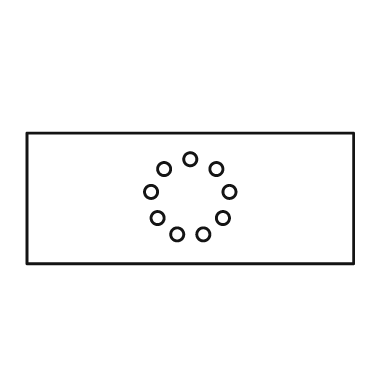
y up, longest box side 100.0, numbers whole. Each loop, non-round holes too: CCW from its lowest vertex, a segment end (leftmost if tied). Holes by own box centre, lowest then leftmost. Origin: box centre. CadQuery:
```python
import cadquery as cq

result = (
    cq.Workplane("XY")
    .moveTo(-50.0, -20.0)
    .lineTo(50.0, -20.0)
    .lineTo(50.0, 20.0)
    .lineTo(-50.0, 20.0)
    .close()
    .moveTo(-4.0, -11.0)
    .circle(2.0)
    .moveTo(4.0, -11.0)
    .circle(2.0)
    .moveTo(-10.0, -6.0)
    .circle(2.0)
    .moveTo(10.0, -6.0)
    .circle(2.0)
    .moveTo(-12.0, 2.0)
    .circle(2.0)
    .moveTo(12.0, 2.0)
    .circle(2.0)
    .moveTo(-8.0, 9.0)
    .circle(2.0)
    .moveTo(8.0, 9.0)
    .circle(2.0)
    .moveTo(0.0, 12.0)
    .circle(2.0)
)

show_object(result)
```